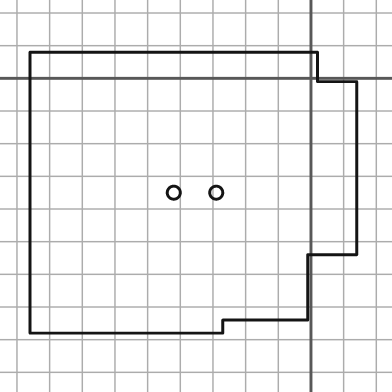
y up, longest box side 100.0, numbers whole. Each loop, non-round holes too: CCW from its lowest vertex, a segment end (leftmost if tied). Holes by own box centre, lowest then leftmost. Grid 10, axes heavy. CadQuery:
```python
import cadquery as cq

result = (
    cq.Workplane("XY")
    .moveTo(-86.0, -78.0)
    .lineTo(-27.0, -78.0)
    .lineTo(-27.0, -74.0)
    .lineTo(-1.0, -74.0)
    .lineTo(-1.0, -54.0)
    .lineTo(14.0, -54.0)
    .lineTo(14.0, -1.0)
    .lineTo(2.0, -1.0)
    .lineTo(2.0, 8.0)
    .lineTo(-86.0, 8.0)
    .close()
    .moveTo(-42.0, -35.0)
    .circle(2.0)
    .moveTo(-29.0, -35.0)
    .circle(2.0)
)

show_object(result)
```